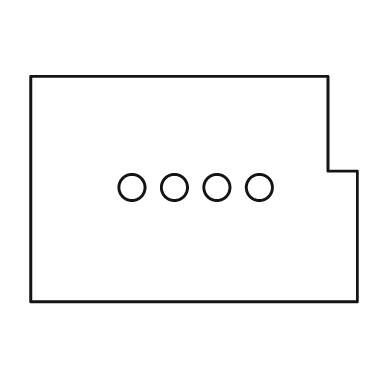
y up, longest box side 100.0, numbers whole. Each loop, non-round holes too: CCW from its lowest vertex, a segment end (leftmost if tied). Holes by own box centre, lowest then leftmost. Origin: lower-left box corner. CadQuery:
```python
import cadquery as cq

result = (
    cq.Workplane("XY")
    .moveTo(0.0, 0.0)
    .lineTo(100.0, 0.0)
    .lineTo(100.0, 40.0)
    .lineTo(91.0, 40.0)
    .lineTo(91.0, 69.0)
    .lineTo(0.0, 69.0)
    .close()
    .moveTo(31.0, 35.0)
    .circle(4.0)
    .moveTo(44.0, 35.0)
    .circle(4.0)
    .moveTo(57.0, 35.0)
    .circle(4.0)
    .moveTo(70.0, 35.0)
    .circle(4.0)
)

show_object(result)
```